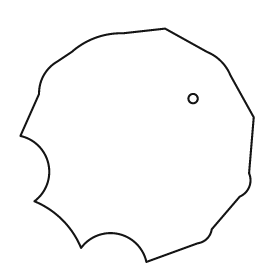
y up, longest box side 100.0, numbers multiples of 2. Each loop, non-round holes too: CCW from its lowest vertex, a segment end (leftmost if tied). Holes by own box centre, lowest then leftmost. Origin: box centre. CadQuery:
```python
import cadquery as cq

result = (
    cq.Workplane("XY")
    .moveTo(4.0, -50.0)
    .lineTo(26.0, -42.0)
    .threePointArc((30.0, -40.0), (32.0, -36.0))
    .lineTo(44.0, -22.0)
    .threePointArc((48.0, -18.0), (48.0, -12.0))
    .lineTo(50.0, 12.0)
    .lineTo(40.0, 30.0)
    .threePointArc((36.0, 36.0), (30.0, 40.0))
    .lineTo(12.0, 50.0)
    .lineTo(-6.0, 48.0)
    .threePointArc((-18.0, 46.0), (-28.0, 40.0))
    .lineTo(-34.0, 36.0)
    .threePointArc((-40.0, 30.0), (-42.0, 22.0))
    .lineTo(-50.0, 4.0)
    .threePointArc((-38.0, -8.0), (-44.0, -24.0))
    .threePointArc((-32.0, -32.0), (-24.0, -44.0))
    .threePointArc((-8.0, -38.0), (4.0, -50.0))
    .close()
    .moveTo(24.0, 20.0)
    .circle(2.0)
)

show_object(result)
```